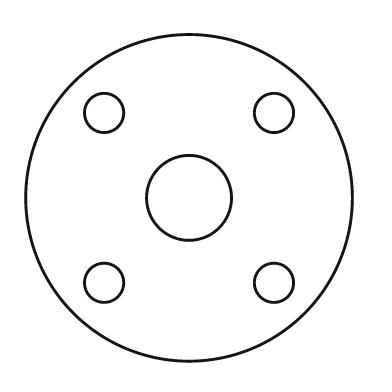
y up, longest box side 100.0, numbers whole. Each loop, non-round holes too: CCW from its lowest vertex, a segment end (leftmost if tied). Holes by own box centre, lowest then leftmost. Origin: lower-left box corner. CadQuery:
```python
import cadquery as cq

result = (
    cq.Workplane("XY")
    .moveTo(50.0, 50.0)
    .circle(50.0)
    .moveTo(24.0, 24.0)
    .circle(6.0)
    .moveTo(76.0, 24.0)
    .circle(6.0)
    .moveTo(50.0, 50.0)
    .circle(13.0)
    .moveTo(24.0, 76.0)
    .circle(6.0)
    .moveTo(76.0, 76.0)
    .circle(6.0)
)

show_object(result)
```